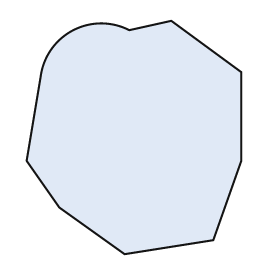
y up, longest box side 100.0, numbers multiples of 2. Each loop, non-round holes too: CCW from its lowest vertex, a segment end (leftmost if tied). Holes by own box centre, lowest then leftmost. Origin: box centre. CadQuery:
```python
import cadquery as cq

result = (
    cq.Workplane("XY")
    .moveTo(-4.0, -50.0)
    .lineTo(34.0, -44.0)
    .lineTo(46.0, -10.0)
    .lineTo(46.0, 28.0)
    .lineTo(16.0, 50.0)
    .lineTo(-2.0, 46.0)
    .threePointArc((-26.0, 46.0), (-40.0, 26.0))
    .lineTo(-46.0, -10.0)
    .lineTo(-32.0, -30.0)
    .close()
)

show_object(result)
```